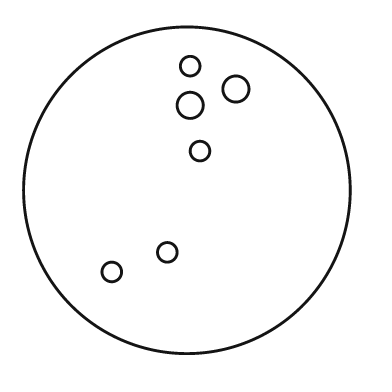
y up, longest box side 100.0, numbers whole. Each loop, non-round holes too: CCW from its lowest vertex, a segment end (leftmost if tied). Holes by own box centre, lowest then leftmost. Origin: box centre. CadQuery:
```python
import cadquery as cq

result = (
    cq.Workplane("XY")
    .moveTo(0.0, 0.0)
    .circle(50.0)
    .moveTo(-23.0, -25.0)
    .circle(3.0)
    .moveTo(-6.0, -19.0)
    .circle(3.0)
    .moveTo(4.0, 12.0)
    .circle(3.0)
    .moveTo(1.0, 26.0)
    .circle(4.0)
    .moveTo(15.0, 31.0)
    .circle(4.0)
    .moveTo(1.0, 38.0)
    .circle(3.0)
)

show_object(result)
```